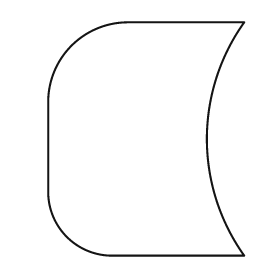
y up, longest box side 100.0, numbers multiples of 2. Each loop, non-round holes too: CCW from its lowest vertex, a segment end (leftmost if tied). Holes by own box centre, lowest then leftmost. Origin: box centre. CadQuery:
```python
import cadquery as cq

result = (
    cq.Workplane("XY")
    .moveTo(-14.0, -50.0)
    .lineTo(42.0, -50.0)
    .threePointArc((26.0, 0.0), (42.0, 50.0))
    .lineTo(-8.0, 50.0)
    .threePointArc((-32.0, 40.0), (-42.0, 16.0))
    .lineTo(-42.0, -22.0)
    .threePointArc((-34.0, -42.0), (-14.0, -50.0))
    .close()
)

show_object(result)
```